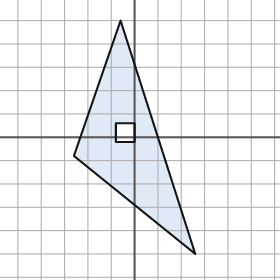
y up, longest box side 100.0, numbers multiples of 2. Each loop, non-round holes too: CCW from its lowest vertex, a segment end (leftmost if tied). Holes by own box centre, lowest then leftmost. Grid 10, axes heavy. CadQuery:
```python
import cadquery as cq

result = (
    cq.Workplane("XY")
    .moveTo(26.0, -50.0)
    .lineTo(-6.0, 50.0)
    .lineTo(-26.0, -8.0)
    .close()
    .moveTo(-8.0, -2.0)
    .lineTo(0.0, -2.0)
    .lineTo(0.0, 6.0)
    .lineTo(-8.0, 6.0)
    .close()
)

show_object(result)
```